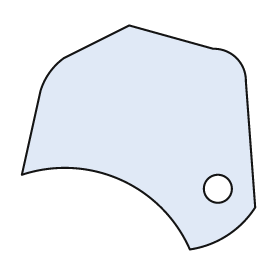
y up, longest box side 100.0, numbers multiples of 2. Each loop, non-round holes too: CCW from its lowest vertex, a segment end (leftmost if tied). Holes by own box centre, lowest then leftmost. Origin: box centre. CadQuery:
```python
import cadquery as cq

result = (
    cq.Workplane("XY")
    .moveTo(22.0, -48.0)
    .threePointArc((38.0, -42.0), (50.0, -30.0))
    .lineTo(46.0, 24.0)
    .threePointArc((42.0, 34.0), (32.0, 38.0))
    .lineTo(-4.0, 48.0)
    .lineTo(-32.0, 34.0)
    .threePointArc((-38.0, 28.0), (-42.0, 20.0))
    .lineTo(-50.0, -16.0)
    .threePointArc((-8.0, -18.0), (22.0, -48.0))
    .close()
    .moveTo(34.0, -22.0)
    .circle(6.0)
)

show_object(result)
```